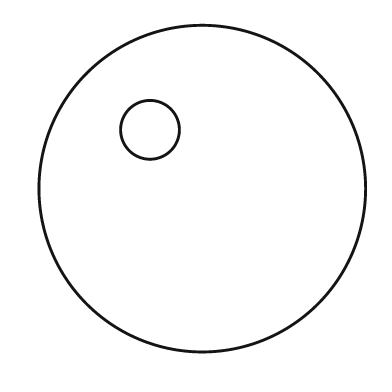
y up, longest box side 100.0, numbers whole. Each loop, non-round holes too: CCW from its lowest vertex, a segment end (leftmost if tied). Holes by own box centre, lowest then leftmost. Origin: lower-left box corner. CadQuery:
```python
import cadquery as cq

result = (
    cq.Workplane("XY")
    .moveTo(50.0, 50.0)
    .circle(50.0)
    .moveTo(34.0, 68.0)
    .circle(9.0)
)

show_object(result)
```